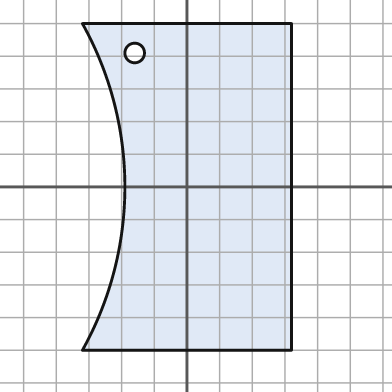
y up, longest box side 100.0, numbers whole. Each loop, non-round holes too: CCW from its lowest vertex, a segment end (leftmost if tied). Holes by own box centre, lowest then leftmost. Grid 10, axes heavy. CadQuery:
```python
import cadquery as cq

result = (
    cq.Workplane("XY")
    .moveTo(-32.0, -50.0)
    .lineTo(32.0, -50.0)
    .lineTo(32.0, 50.0)
    .lineTo(-32.0, 50.0)
    .threePointArc((-19.0, 0.0), (-32.0, -50.0))
    .close()
    .moveTo(-16.0, 41.0)
    .circle(3.0)
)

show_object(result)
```